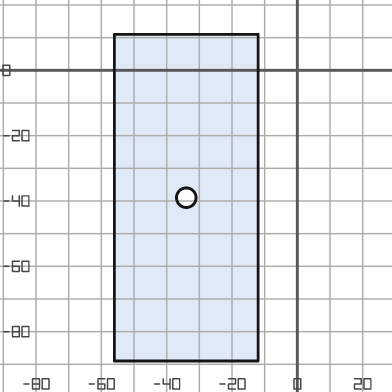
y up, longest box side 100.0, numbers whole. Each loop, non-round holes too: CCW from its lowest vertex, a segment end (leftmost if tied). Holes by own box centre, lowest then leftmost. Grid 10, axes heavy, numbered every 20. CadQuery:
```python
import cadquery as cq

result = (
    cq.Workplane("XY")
    .moveTo(-56.0, -89.0)
    .lineTo(-12.0, -89.0)
    .lineTo(-12.0, 11.0)
    .lineTo(-56.0, 11.0)
    .close()
    .moveTo(-34.0, -39.0)
    .circle(3.0)
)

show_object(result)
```